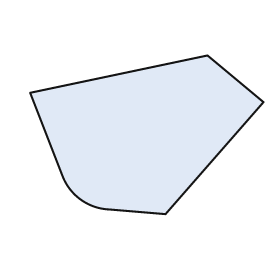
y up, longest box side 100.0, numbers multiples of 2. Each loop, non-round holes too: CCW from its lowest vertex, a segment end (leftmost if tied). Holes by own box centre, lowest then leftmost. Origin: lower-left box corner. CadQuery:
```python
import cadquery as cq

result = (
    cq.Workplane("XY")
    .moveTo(58.0, 0.0)
    .lineTo(100.0, 48.0)
    .lineTo(76.0, 68.0)
    .lineTo(0.0, 52.0)
    .lineTo(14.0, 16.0)
    .threePointArc((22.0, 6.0), (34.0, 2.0))
    .close()
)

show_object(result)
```